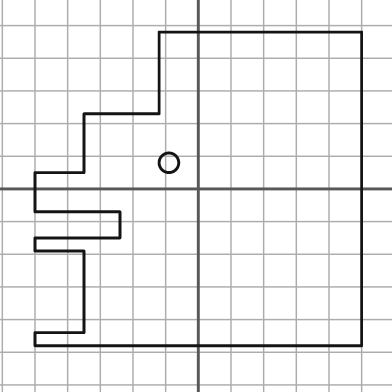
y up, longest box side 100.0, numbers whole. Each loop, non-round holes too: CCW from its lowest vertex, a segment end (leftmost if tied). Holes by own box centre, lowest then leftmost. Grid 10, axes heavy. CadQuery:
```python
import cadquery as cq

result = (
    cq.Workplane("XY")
    .moveTo(-50.0, -48.0)
    .lineTo(50.0, -48.0)
    .lineTo(50.0, 48.0)
    .lineTo(-12.0, 48.0)
    .lineTo(-12.0, 23.0)
    .lineTo(-35.0, 23.0)
    .lineTo(-35.0, 5.0)
    .lineTo(-50.0, 5.0)
    .lineTo(-50.0, -7.0)
    .lineTo(-24.0, -7.0)
    .lineTo(-24.0, -15.0)
    .lineTo(-50.0, -15.0)
    .lineTo(-50.0, -19.0)
    .lineTo(-35.0, -19.0)
    .lineTo(-35.0, -44.0)
    .lineTo(-50.0, -44.0)
    .close()
    .moveTo(-9.0, 8.0)
    .circle(3.0)
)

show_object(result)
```